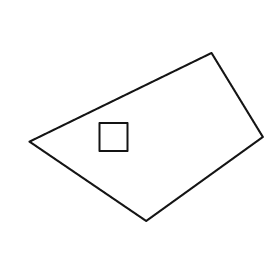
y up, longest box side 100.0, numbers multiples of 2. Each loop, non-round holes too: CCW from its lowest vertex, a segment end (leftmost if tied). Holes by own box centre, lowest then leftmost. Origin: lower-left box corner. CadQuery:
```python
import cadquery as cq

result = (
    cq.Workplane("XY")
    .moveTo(50.0, 0.0)
    .lineTo(100.0, 36.0)
    .lineTo(78.0, 72.0)
    .lineTo(0.0, 34.0)
    .close()
    .moveTo(30.0, 30.0)
    .lineTo(42.0, 30.0)
    .lineTo(42.0, 42.0)
    .lineTo(30.0, 42.0)
    .close()
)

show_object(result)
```